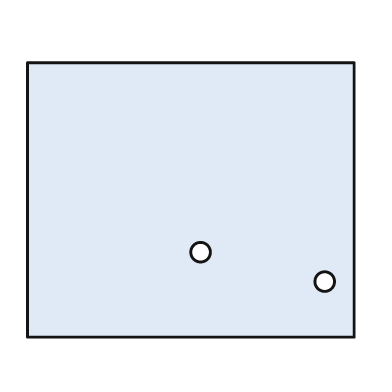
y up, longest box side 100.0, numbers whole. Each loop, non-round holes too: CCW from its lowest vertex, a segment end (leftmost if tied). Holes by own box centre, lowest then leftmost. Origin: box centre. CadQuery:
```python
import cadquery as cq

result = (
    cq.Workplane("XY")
    .moveTo(-50.0, -42.0)
    .lineTo(50.0, -42.0)
    .lineTo(50.0, 42.0)
    .lineTo(-50.0, 42.0)
    .close()
    .moveTo(41.0, -25.0)
    .circle(3.0)
    .moveTo(3.0, -16.0)
    .circle(3.0)
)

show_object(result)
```